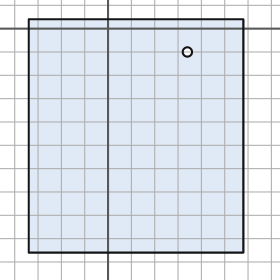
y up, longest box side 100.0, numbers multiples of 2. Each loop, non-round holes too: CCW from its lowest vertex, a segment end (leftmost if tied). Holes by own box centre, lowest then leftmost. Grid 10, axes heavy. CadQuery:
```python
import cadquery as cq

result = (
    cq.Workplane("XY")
    .moveTo(-34.0, -96.0)
    .lineTo(58.0, -96.0)
    .lineTo(58.0, 4.0)
    .lineTo(-34.0, 4.0)
    .close()
    .moveTo(34.0, -10.0)
    .circle(2.0)
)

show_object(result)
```